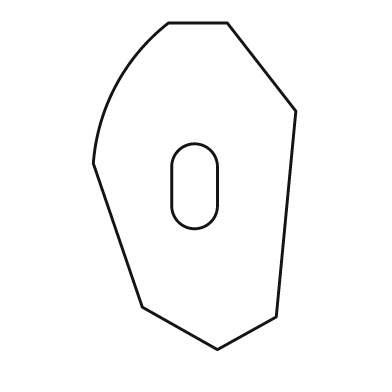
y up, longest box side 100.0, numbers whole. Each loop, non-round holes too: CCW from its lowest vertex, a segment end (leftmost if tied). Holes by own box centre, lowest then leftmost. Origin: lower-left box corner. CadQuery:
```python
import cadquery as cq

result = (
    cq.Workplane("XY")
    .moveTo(38.0, 0.0)
    .lineTo(56.0, 10.0)
    .lineTo(62.0, 73.0)
    .lineTo(41.0, 100.0)
    .lineTo(23.0, 100.0)
    .threePointArc((7.0, 81.0), (0.0, 57.0))
    .lineTo(15.0, 13.0)
    .close()
    .moveTo(24.0, 44.0)
    .threePointArc((31.0, 37.0), (38.0, 44.0))
    .lineTo(38.0, 56.0)
    .threePointArc((31.0, 63.0), (24.0, 56.0))
    .close()
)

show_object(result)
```